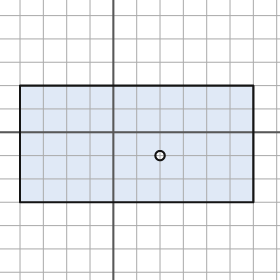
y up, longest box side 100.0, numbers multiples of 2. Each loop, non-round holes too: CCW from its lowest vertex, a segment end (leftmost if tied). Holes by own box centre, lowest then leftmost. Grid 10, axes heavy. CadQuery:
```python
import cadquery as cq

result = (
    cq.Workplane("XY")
    .moveTo(-40.0, -30.0)
    .lineTo(60.0, -30.0)
    .lineTo(60.0, 20.0)
    .lineTo(-40.0, 20.0)
    .close()
    .moveTo(20.0, -10.0)
    .circle(2.0)
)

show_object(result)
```